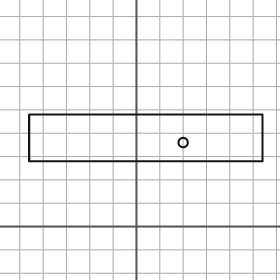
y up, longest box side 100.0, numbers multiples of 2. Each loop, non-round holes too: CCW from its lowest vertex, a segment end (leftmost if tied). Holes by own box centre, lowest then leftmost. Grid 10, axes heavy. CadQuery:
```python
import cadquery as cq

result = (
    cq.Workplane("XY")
    .moveTo(-46.0, 28.0)
    .lineTo(54.0, 28.0)
    .lineTo(54.0, 48.0)
    .lineTo(-46.0, 48.0)
    .close()
    .moveTo(20.0, 36.0)
    .circle(2.0)
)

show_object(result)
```